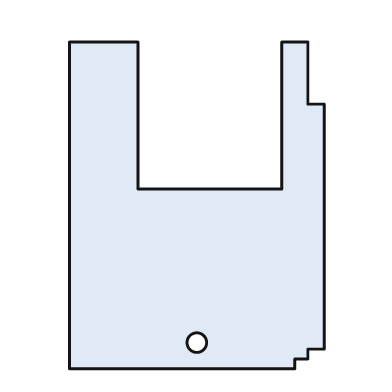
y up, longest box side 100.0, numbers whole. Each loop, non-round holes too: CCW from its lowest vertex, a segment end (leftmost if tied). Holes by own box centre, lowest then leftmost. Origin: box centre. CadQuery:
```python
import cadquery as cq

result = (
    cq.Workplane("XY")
    .moveTo(-39.0, -50.0)
    .lineTo(30.0, -50.0)
    .lineTo(30.0, -47.0)
    .lineTo(34.0, -47.0)
    .lineTo(34.0, -44.0)
    .lineTo(39.0, -44.0)
    .lineTo(39.0, 31.0)
    .lineTo(34.0, 31.0)
    .lineTo(34.0, 50.0)
    .lineTo(26.0, 50.0)
    .lineTo(26.0, 5.0)
    .lineTo(-18.0, 5.0)
    .lineTo(-18.0, 50.0)
    .lineTo(-39.0, 50.0)
    .close()
    .moveTo(0.0, -42.0)
    .circle(3.0)
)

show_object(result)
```